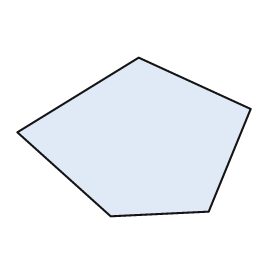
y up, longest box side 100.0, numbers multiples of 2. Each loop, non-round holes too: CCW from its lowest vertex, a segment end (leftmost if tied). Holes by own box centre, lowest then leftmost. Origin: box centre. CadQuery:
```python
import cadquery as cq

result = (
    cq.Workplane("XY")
    .moveTo(-10.0, -34.0)
    .lineTo(32.0, -32.0)
    .lineTo(50.0, 12.0)
    .lineTo(2.0, 34.0)
    .lineTo(-50.0, 2.0)
    .close()
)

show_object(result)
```